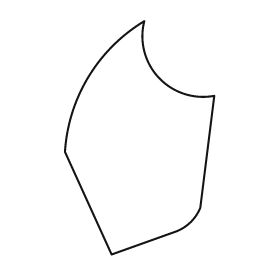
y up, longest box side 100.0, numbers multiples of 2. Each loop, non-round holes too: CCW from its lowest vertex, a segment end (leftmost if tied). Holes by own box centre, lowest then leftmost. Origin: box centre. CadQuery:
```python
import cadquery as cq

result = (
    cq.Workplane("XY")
    .moveTo(-12.0, -50.0)
    .lineTo(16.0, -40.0)
    .threePointArc((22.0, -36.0), (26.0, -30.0))
    .lineTo(32.0, 18.0)
    .threePointArc((8.0, 26.0), (2.0, 50.0))
    .threePointArc((-22.0, 26.0), (-32.0, -6.0))
    .close()
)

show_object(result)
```